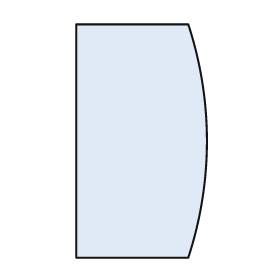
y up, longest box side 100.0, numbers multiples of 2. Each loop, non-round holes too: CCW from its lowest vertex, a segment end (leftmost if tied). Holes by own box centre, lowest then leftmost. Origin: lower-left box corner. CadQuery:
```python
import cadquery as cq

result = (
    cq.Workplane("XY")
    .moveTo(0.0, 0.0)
    .lineTo(48.0, 0.0)
    .threePointArc((56.0, 50.0), (48.0, 100.0))
    .lineTo(0.0, 100.0)
    .close()
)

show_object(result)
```